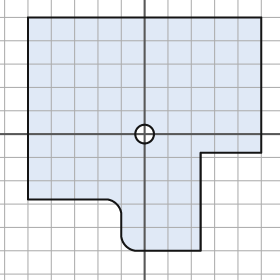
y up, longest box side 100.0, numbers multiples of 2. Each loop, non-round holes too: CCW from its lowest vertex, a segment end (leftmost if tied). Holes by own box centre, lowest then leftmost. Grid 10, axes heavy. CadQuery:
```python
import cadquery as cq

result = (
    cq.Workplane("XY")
    .moveTo(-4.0, -50.0)
    .lineTo(24.0, -50.0)
    .lineTo(24.0, -8.0)
    .lineTo(50.0, -8.0)
    .lineTo(50.0, 50.0)
    .lineTo(-50.0, 50.0)
    .lineTo(-50.0, -28.0)
    .lineTo(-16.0, -28.0)
    .threePointArc((-12.0, -30.0), (-10.0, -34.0))
    .lineTo(-10.0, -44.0)
    .threePointArc((-8.0, -48.0), (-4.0, -50.0))
    .close()
    .moveTo(0.0, 0.0)
    .circle(4.0)
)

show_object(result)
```